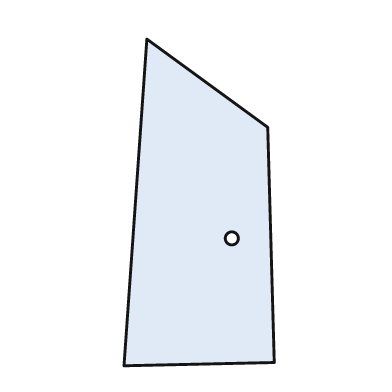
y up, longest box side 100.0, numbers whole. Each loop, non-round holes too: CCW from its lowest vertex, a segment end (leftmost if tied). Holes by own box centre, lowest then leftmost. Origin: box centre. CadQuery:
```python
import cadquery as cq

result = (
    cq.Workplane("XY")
    .moveTo(-23.0, -50.0)
    .lineTo(23.0, -49.0)
    .lineTo(21.0, 23.0)
    .lineTo(-16.0, 50.0)
    .close()
    .moveTo(10.0, -11.0)
    .circle(2.0)
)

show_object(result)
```